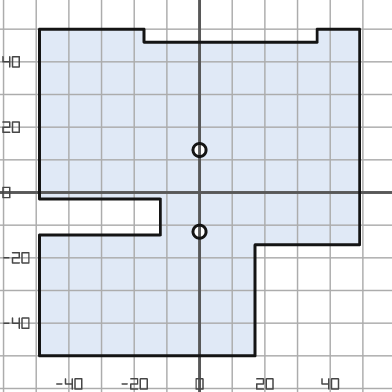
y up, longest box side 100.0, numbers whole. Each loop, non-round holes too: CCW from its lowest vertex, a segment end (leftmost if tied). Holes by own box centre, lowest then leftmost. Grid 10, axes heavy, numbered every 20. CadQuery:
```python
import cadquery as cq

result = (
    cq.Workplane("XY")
    .moveTo(-49.0, -50.0)
    .lineTo(17.0, -50.0)
    .lineTo(17.0, -16.0)
    .lineTo(49.0, -16.0)
    .lineTo(49.0, 50.0)
    .lineTo(36.0, 50.0)
    .lineTo(36.0, 46.0)
    .lineTo(-17.0, 46.0)
    .lineTo(-17.0, 50.0)
    .lineTo(-49.0, 50.0)
    .lineTo(-49.0, -2.0)
    .lineTo(-12.0, -2.0)
    .lineTo(-12.0, -13.0)
    .lineTo(-49.0, -13.0)
    .close()
    .moveTo(0.0, -12.0)
    .circle(2.0)
    .moveTo(0.0, 13.0)
    .circle(2.0)
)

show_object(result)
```